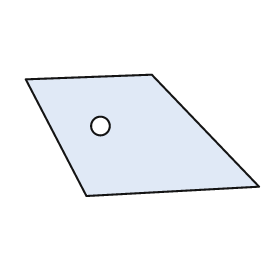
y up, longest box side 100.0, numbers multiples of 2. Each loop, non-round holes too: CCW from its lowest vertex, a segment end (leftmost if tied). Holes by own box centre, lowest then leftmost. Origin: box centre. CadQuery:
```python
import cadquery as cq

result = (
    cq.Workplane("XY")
    .moveTo(-24.0, -26.0)
    .lineTo(50.0, -22.0)
    .lineTo(4.0, 26.0)
    .lineTo(-50.0, 24.0)
    .close()
    .moveTo(-18.0, 4.0)
    .circle(4.0)
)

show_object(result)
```